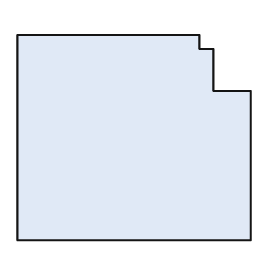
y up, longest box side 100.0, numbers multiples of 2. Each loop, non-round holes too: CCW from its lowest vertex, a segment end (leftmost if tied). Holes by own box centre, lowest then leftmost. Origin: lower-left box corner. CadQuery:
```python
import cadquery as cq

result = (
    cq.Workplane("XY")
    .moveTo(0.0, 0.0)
    .lineTo(100.0, 0.0)
    .lineTo(100.0, 64.0)
    .lineTo(84.0, 64.0)
    .lineTo(84.0, 82.0)
    .lineTo(78.0, 82.0)
    .lineTo(78.0, 88.0)
    .lineTo(0.0, 88.0)
    .close()
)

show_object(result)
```